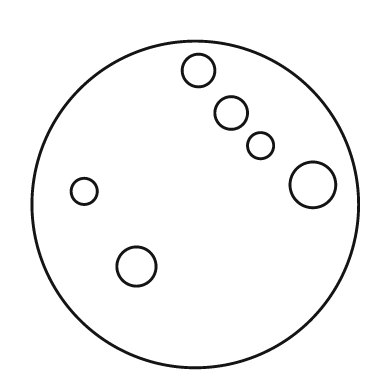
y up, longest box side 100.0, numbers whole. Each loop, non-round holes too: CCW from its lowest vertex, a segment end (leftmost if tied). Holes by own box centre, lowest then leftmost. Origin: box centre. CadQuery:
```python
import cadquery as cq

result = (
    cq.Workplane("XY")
    .moveTo(0.0, 0.0)
    .circle(50.0)
    .moveTo(-18.0, -19.0)
    .circle(6.0)
    .moveTo(-34.0, 4.0)
    .circle(4.0)
    .moveTo(36.0, 6.0)
    .circle(7.0)
    .moveTo(20.0, 18.0)
    .circle(4.0)
    .moveTo(11.0, 28.0)
    .circle(5.0)
    .moveTo(1.0, 41.0)
    .circle(5.0)
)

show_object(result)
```